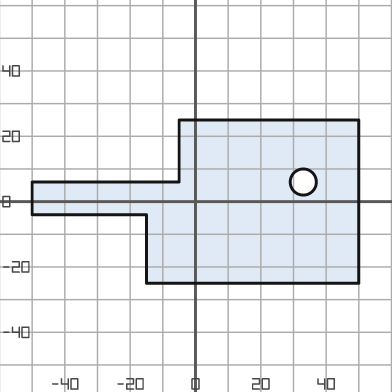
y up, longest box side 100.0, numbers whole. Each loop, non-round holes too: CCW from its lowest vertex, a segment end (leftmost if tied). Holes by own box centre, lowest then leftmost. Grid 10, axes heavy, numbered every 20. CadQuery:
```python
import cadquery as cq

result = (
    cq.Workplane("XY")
    .moveTo(-15.0, -25.0)
    .lineTo(50.0, -25.0)
    .lineTo(50.0, 25.0)
    .lineTo(-5.0, 25.0)
    .lineTo(-5.0, 6.0)
    .lineTo(-50.0, 6.0)
    .lineTo(-50.0, -4.0)
    .lineTo(-15.0, -4.0)
    .close()
    .moveTo(33.0, 6.0)
    .circle(4.0)
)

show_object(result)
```